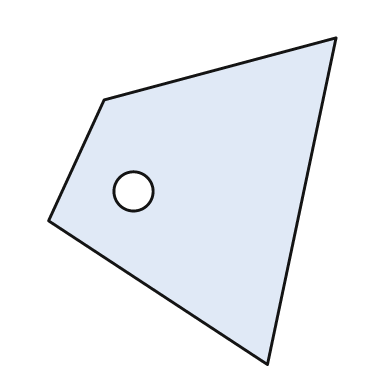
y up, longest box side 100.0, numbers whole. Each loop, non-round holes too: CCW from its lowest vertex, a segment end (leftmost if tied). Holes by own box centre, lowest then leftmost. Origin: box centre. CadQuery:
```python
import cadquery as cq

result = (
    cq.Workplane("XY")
    .moveTo(23.0, -50.0)
    .lineTo(44.0, 50.0)
    .lineTo(-27.0, 31.0)
    .lineTo(-44.0, -6.0)
    .close()
    .moveTo(-18.0, 3.0)
    .circle(6.0)
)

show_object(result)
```